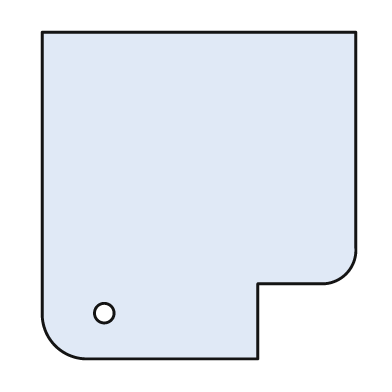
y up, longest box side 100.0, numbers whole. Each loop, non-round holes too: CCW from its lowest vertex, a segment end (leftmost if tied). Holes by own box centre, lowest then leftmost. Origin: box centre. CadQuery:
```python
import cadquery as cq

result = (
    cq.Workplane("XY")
    .moveTo(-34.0, -50.0)
    .lineTo(18.0, -50.0)
    .lineTo(18.0, -27.0)
    .lineTo(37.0, -27.0)
    .threePointArc((45.0, -24.0), (48.0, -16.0))
    .lineTo(48.0, 50.0)
    .lineTo(-48.0, 50.0)
    .lineTo(-48.0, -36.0)
    .threePointArc((-44.0, -46.0), (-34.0, -50.0))
    .close()
    .moveTo(-29.0, -36.0)
    .circle(3.0)
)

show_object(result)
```